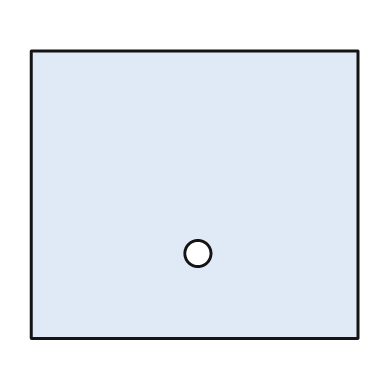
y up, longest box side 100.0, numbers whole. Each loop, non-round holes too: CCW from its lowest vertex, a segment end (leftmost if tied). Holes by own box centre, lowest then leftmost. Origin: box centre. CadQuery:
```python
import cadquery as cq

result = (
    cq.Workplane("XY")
    .moveTo(-50.0, -44.0)
    .lineTo(50.0, -44.0)
    .lineTo(50.0, 44.0)
    .lineTo(-50.0, 44.0)
    .close()
    .moveTo(1.0, -18.0)
    .circle(4.0)
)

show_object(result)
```